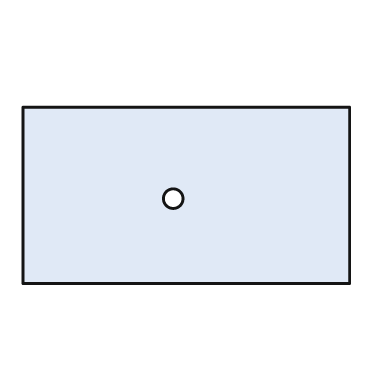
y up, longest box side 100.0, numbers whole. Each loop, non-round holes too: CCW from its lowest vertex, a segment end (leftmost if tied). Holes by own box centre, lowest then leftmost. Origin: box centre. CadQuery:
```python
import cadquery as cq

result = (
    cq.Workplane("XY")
    .moveTo(-50.0, -27.0)
    .lineTo(50.0, -27.0)
    .lineTo(50.0, 27.0)
    .lineTo(-50.0, 27.0)
    .close()
    .moveTo(-4.0, -1.0)
    .circle(3.0)
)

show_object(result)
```